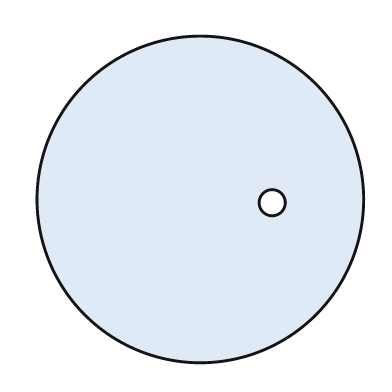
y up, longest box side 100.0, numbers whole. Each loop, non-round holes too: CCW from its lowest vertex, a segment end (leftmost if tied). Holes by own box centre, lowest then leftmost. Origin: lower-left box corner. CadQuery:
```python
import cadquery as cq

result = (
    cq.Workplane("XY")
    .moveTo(50.0, 50.0)
    .circle(50.0)
    .moveTo(72.0, 49.0)
    .circle(4.0)
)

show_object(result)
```